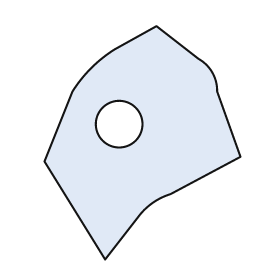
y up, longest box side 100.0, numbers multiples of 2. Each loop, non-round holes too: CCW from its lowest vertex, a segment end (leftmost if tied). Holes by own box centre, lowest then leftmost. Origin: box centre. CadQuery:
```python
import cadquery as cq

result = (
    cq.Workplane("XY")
    .moveTo(-16.0, -50.0)
    .lineTo(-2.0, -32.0)
    .threePointArc((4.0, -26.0), (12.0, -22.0))
    .lineTo(42.0, -6.0)
    .lineTo(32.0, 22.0)
    .threePointArc((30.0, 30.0), (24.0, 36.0))
    .lineTo(6.0, 50.0)
    .lineTo(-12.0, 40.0)
    .threePointArc((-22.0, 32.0), (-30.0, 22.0))
    .lineTo(-42.0, -8.0)
    .close()
    .moveTo(-10.0, 8.0)
    .circle(10.0)
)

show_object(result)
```